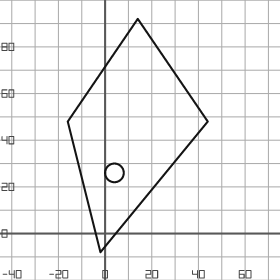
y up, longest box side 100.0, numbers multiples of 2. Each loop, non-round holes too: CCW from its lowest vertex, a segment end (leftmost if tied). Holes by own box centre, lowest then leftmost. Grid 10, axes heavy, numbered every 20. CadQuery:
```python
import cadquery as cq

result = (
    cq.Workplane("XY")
    .moveTo(-2.0, -8.0)
    .lineTo(44.0, 48.0)
    .lineTo(14.0, 92.0)
    .lineTo(-16.0, 48.0)
    .close()
    .moveTo(4.0, 26.0)
    .circle(4.0)
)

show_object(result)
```